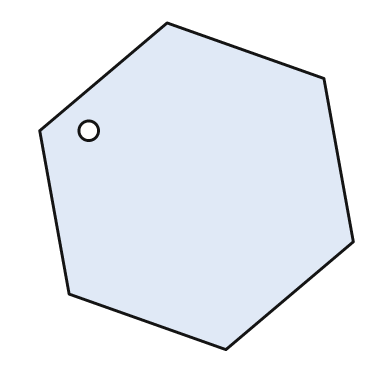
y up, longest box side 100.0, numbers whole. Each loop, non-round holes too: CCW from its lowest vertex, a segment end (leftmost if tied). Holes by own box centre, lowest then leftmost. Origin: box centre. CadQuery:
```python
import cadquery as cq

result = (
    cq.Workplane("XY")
    .moveTo(9.0, -50.0)
    .lineTo(48.0, -17.0)
    .lineTo(39.0, 33.0)
    .lineTo(-9.0, 50.0)
    .lineTo(-48.0, 17.0)
    .lineTo(-39.0, -33.0)
    .close()
    .moveTo(-33.0, 17.0)
    .circle(3.0)
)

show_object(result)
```